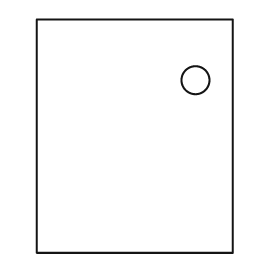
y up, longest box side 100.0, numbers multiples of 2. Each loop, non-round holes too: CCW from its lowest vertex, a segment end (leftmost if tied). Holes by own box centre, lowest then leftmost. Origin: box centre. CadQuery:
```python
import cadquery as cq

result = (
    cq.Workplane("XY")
    .moveTo(-42.0, -50.0)
    .lineTo(42.0, -50.0)
    .lineTo(42.0, 50.0)
    .lineTo(-42.0, 50.0)
    .close()
    .moveTo(26.0, 24.0)
    .circle(6.0)
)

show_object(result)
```